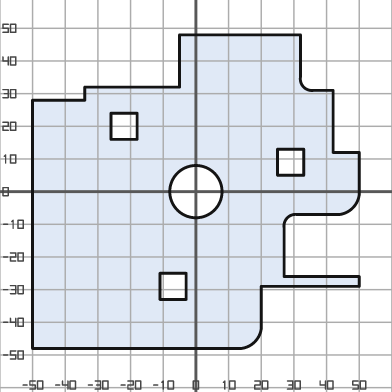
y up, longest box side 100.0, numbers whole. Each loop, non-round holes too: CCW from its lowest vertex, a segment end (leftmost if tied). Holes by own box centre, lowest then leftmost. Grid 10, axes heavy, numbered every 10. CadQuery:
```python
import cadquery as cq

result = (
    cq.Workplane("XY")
    .moveTo(-50.0, -48.0)
    .lineTo(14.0, -48.0)
    .threePointArc((18.0, -46.0), (20.0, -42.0))
    .lineTo(20.0, -29.0)
    .lineTo(50.0, -29.0)
    .lineTo(50.0, -26.0)
    .lineTo(27.0, -26.0)
    .lineTo(27.0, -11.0)
    .threePointArc((28.0, -8.0), (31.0, -7.0))
    .lineTo(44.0, -7.0)
    .threePointArc((48.0, -5.0), (50.0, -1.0))
    .lineTo(50.0, 12.0)
    .lineTo(42.0, 12.0)
    .lineTo(42.0, 31.0)
    .lineTo(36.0, 31.0)
    .threePointArc((33.0, 32.0), (32.0, 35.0))
    .lineTo(32.0, 48.0)
    .lineTo(-5.0, 48.0)
    .lineTo(-5.0, 32.0)
    .lineTo(-34.0, 32.0)
    .lineTo(-34.0, 28.0)
    .lineTo(-50.0, 28.0)
    .close()
    .moveTo(-11.0, -33.0)
    .lineTo(-3.0, -33.0)
    .lineTo(-3.0, -25.0)
    .lineTo(-11.0, -25.0)
    .close()
    .moveTo(0.0, 0.0)
    .circle(8.0)
    .moveTo(25.0, 5.0)
    .lineTo(33.0, 5.0)
    .lineTo(33.0, 13.0)
    .lineTo(25.0, 13.0)
    .close()
    .moveTo(-26.0, 16.0)
    .lineTo(-18.0, 16.0)
    .lineTo(-18.0, 24.0)
    .lineTo(-26.0, 24.0)
    .close()
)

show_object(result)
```